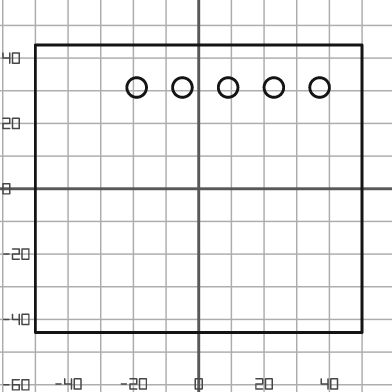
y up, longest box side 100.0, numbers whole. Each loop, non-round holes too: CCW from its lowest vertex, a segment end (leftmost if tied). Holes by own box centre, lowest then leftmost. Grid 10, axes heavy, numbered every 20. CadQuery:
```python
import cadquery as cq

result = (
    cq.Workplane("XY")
    .moveTo(-50.0, -44.0)
    .lineTo(50.0, -44.0)
    .lineTo(50.0, 44.0)
    .lineTo(-50.0, 44.0)
    .close()
    .moveTo(-19.0, 31.0)
    .circle(3.0)
    .moveTo(-5.0, 31.0)
    .circle(3.0)
    .moveTo(9.0, 31.0)
    .circle(3.0)
    .moveTo(23.0, 31.0)
    .circle(3.0)
    .moveTo(37.0, 31.0)
    .circle(3.0)
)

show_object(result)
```